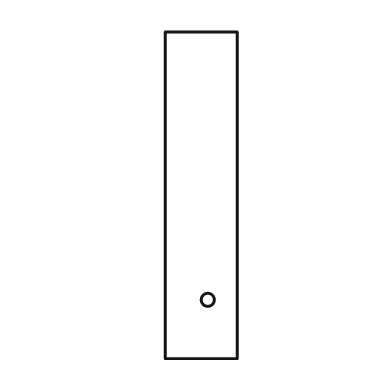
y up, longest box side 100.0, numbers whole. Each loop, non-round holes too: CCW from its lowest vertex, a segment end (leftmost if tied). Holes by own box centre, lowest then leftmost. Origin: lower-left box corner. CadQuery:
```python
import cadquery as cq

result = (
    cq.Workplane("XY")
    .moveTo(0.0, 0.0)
    .lineTo(22.0, 0.0)
    .lineTo(22.0, 100.0)
    .lineTo(0.0, 100.0)
    .close()
    .moveTo(13.0, 18.0)
    .circle(2.0)
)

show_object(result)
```